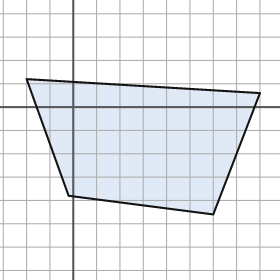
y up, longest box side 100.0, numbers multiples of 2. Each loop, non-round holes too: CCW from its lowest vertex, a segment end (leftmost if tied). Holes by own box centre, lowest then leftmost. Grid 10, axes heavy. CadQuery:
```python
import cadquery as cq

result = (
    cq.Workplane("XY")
    .moveTo(60.0, -46.0)
    .lineTo(80.0, 6.0)
    .lineTo(-20.0, 12.0)
    .lineTo(-2.0, -38.0)
    .close()
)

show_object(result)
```